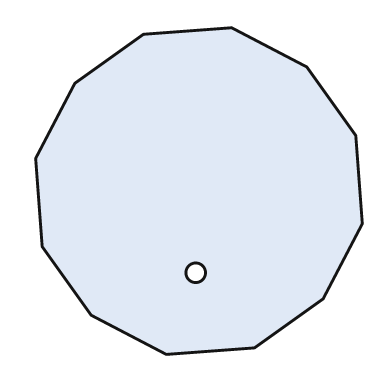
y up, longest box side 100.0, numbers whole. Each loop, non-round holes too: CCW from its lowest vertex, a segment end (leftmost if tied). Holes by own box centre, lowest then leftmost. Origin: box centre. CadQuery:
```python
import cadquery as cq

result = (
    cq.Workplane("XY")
    .moveTo(-10.0, -50.0)
    .lineTo(17.0, -48.0)
    .lineTo(38.0, -33.0)
    .lineTo(50.0, -10.0)
    .lineTo(48.0, 17.0)
    .lineTo(33.0, 38.0)
    .lineTo(10.0, 50.0)
    .lineTo(-17.0, 48.0)
    .lineTo(-38.0, 33.0)
    .lineTo(-50.0, 10.0)
    .lineTo(-48.0, -17.0)
    .lineTo(-33.0, -38.0)
    .close()
    .moveTo(-1.0, -25.0)
    .circle(3.0)
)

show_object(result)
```